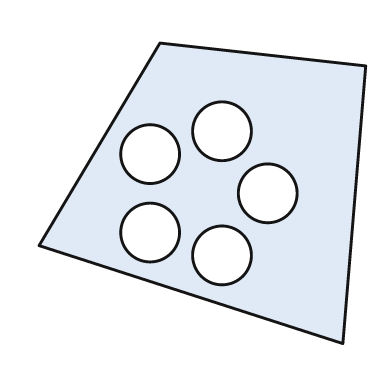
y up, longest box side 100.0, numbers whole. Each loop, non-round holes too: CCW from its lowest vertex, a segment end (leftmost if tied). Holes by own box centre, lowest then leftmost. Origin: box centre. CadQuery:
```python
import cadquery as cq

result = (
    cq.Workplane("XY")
    .moveTo(43.0, -46.0)
    .lineTo(50.0, 39.0)
    .lineTo(-13.0, 46.0)
    .lineTo(-50.0, -16.0)
    .close()
    .moveTo(6.0, -19.0)
    .circle(9.0)
    .moveTo(-16.0, -12.0)
    .circle(9.0)
    .moveTo(20.0, 0.0)
    .circle(9.0)
    .moveTo(-16.0, 12.0)
    .circle(9.0)
    .moveTo(6.0, 19.0)
    .circle(9.0)
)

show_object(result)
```